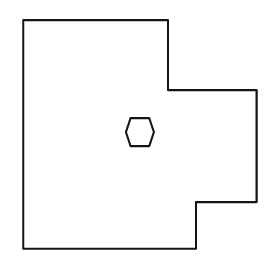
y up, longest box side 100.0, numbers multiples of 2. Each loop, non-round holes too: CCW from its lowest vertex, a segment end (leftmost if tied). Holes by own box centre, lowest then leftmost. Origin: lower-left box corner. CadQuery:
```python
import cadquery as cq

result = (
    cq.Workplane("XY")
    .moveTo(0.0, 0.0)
    .lineTo(74.0, 0.0)
    .lineTo(74.0, 20.0)
    .lineTo(100.0, 20.0)
    .lineTo(100.0, 68.0)
    .lineTo(62.0, 68.0)
    .lineTo(62.0, 98.0)
    .lineTo(0.0, 98.0)
    .close()
    .moveTo(46.0, 44.0)
    .lineTo(54.0, 44.0)
    .lineTo(56.0, 50.0)
    .lineTo(54.0, 56.0)
    .lineTo(46.0, 56.0)
    .lineTo(44.0, 50.0)
    .close()
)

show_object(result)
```